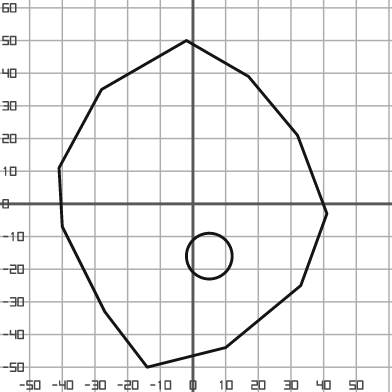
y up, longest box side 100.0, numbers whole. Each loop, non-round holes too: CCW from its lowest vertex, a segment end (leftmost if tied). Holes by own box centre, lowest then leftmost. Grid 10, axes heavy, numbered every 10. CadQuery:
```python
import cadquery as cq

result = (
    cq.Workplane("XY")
    .moveTo(-14.0, -50.0)
    .lineTo(10.0, -44.0)
    .lineTo(33.0, -25.0)
    .lineTo(41.0, -3.0)
    .lineTo(32.0, 21.0)
    .lineTo(17.0, 39.0)
    .lineTo(-2.0, 50.0)
    .lineTo(-28.0, 35.0)
    .lineTo(-41.0, 11.0)
    .lineTo(-40.0, -7.0)
    .lineTo(-27.0, -33.0)
    .close()
    .moveTo(5.0, -16.0)
    .circle(7.0)
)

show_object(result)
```